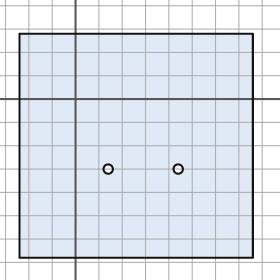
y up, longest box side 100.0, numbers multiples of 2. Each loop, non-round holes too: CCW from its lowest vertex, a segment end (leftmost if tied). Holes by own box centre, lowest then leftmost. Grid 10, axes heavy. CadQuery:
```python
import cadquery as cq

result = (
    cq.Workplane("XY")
    .moveTo(-24.0, -68.0)
    .lineTo(76.0, -68.0)
    .lineTo(76.0, 28.0)
    .lineTo(-24.0, 28.0)
    .close()
    .moveTo(14.0, -30.0)
    .circle(2.0)
    .moveTo(44.0, -30.0)
    .circle(2.0)
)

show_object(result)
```